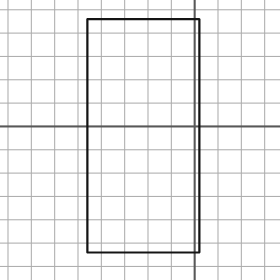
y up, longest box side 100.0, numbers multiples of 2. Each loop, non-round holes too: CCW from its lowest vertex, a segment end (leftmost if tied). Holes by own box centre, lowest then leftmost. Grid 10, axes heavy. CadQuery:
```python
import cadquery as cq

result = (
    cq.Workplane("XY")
    .moveTo(-46.0, -54.0)
    .lineTo(2.0, -54.0)
    .lineTo(2.0, 46.0)
    .lineTo(-46.0, 46.0)
    .close()
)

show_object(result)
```